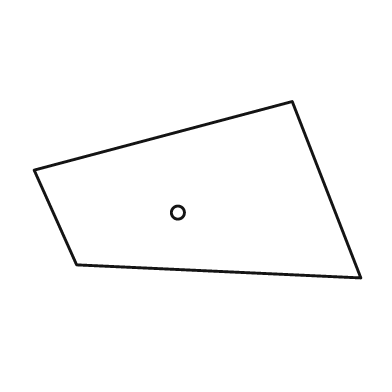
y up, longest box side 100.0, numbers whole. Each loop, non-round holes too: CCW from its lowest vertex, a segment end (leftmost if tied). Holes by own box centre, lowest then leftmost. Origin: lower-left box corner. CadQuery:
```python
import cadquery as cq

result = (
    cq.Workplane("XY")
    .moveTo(100.0, 0.0)
    .lineTo(79.0, 54.0)
    .lineTo(0.0, 33.0)
    .lineTo(13.0, 4.0)
    .close()
    .moveTo(44.0, 20.0)
    .circle(2.0)
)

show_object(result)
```